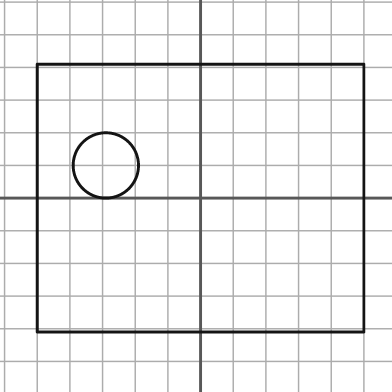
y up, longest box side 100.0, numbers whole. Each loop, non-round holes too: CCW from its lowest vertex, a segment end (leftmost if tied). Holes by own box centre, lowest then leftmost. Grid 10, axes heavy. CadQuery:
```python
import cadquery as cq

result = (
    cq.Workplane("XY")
    .moveTo(-50.0, -41.0)
    .lineTo(50.0, -41.0)
    .lineTo(50.0, 41.0)
    .lineTo(-50.0, 41.0)
    .close()
    .moveTo(-29.0, 10.0)
    .circle(10.0)
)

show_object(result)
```